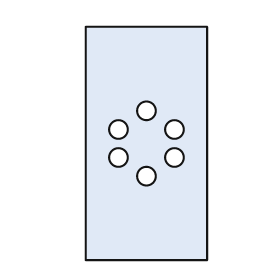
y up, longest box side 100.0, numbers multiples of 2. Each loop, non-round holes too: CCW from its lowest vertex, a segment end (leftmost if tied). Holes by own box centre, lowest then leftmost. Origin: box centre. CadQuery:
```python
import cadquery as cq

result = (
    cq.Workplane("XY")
    .moveTo(-26.0, -50.0)
    .lineTo(26.0, -50.0)
    .lineTo(26.0, 50.0)
    .lineTo(-26.0, 50.0)
    .close()
    .moveTo(0.0, -14.0)
    .circle(4.0)
    .moveTo(-12.0, -6.0)
    .circle(4.0)
    .moveTo(12.0, -6.0)
    .circle(4.0)
    .moveTo(-12.0, 6.0)
    .circle(4.0)
    .moveTo(12.0, 6.0)
    .circle(4.0)
    .moveTo(0.0, 14.0)
    .circle(4.0)
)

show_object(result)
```